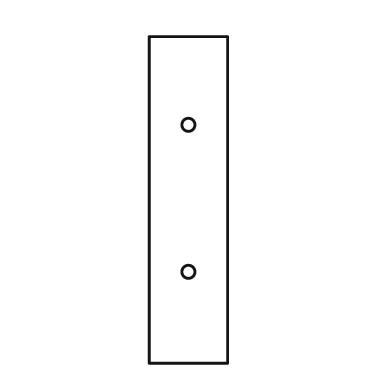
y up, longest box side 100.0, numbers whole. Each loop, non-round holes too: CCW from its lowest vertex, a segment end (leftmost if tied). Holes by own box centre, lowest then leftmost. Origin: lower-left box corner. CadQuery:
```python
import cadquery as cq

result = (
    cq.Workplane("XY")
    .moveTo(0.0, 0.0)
    .lineTo(24.0, 0.0)
    .lineTo(24.0, 100.0)
    .lineTo(0.0, 100.0)
    .close()
    .moveTo(12.0, 28.0)
    .circle(2.0)
    .moveTo(12.0, 73.0)
    .circle(2.0)
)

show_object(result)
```